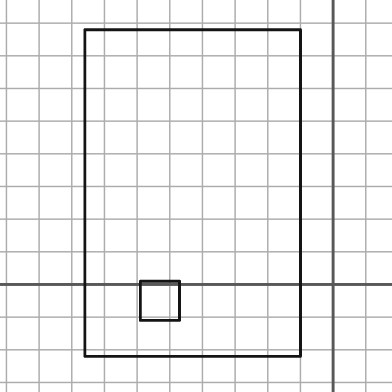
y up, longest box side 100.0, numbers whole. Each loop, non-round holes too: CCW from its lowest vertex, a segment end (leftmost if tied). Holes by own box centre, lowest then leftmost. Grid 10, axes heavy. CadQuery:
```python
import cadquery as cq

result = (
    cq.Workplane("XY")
    .moveTo(-76.0, -22.0)
    .lineTo(-10.0, -22.0)
    .lineTo(-10.0, 78.0)
    .lineTo(-76.0, 78.0)
    .close()
    .moveTo(-59.0, -11.0)
    .lineTo(-47.0, -11.0)
    .lineTo(-47.0, 1.0)
    .lineTo(-59.0, 1.0)
    .close()
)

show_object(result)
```